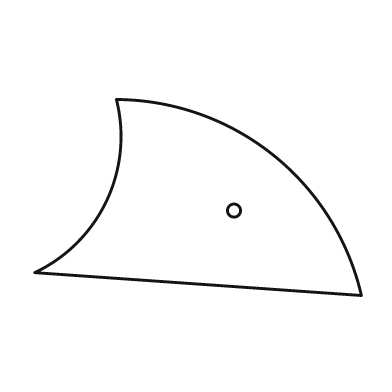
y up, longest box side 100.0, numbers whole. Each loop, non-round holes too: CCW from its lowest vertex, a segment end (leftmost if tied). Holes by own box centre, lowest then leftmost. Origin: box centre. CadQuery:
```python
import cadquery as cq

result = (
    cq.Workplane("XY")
    .moveTo(50.0, -30.0)
    .threePointArc((23.0, 13.0), (-25.0, 30.0))
    .threePointArc((-28.0, -1.0), (-50.0, -23.0))
    .close()
    .moveTo(11.0, -4.0)
    .circle(2.0)
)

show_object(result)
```